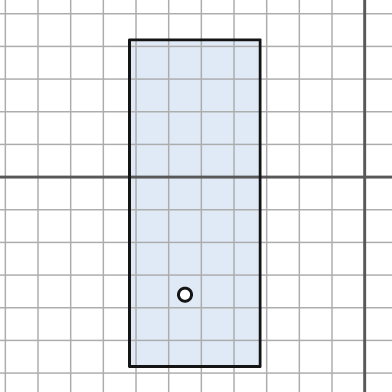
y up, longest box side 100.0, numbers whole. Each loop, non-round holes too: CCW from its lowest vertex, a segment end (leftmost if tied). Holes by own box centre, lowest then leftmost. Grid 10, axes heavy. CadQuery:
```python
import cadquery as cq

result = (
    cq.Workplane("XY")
    .moveTo(-72.0, -58.0)
    .lineTo(-32.0, -58.0)
    .lineTo(-32.0, 42.0)
    .lineTo(-72.0, 42.0)
    .close()
    .moveTo(-55.0, -36.0)
    .circle(2.0)
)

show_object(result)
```